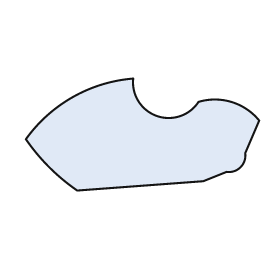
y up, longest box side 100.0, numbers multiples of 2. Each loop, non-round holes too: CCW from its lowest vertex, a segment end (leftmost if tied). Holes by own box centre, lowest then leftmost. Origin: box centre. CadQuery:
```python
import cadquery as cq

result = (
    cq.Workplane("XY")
    .moveTo(-28.0, -24.0)
    .lineTo(26.0, -20.0)
    .lineTo(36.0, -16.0)
    .threePointArc((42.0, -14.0), (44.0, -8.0))
    .lineTo(50.0, 6.0)
    .threePointArc((38.0, 14.0), (24.0, 14.0))
    .threePointArc((6.0, 8.0), (-4.0, 24.0))
    .threePointArc((-30.0, 16.0), (-50.0, -2.0))
    .threePointArc((-40.0, -14.0), (-28.0, -24.0))
    .close()
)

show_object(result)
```